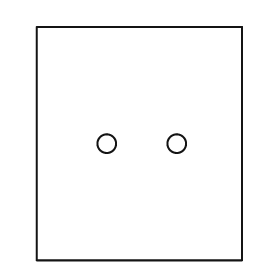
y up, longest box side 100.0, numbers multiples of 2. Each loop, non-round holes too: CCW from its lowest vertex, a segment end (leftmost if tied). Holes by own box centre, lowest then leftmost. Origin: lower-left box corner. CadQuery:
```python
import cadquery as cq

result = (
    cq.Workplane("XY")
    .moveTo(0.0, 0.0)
    .lineTo(88.0, 0.0)
    .lineTo(88.0, 100.0)
    .lineTo(0.0, 100.0)
    .close()
    .moveTo(30.0, 50.0)
    .circle(4.0)
    .moveTo(60.0, 50.0)
    .circle(4.0)
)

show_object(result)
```